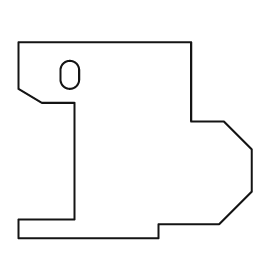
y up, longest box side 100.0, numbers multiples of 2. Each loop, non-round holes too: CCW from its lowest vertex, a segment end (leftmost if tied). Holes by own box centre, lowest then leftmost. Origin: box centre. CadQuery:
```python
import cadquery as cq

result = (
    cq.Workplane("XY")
    .moveTo(-50.0, -42.0)
    .lineTo(10.0, -42.0)
    .lineTo(10.0, -36.0)
    .lineTo(36.0, -36.0)
    .lineTo(50.0, -22.0)
    .lineTo(50.0, -4.0)
    .lineTo(38.0, 8.0)
    .lineTo(24.0, 8.0)
    .lineTo(24.0, 42.0)
    .lineTo(-50.0, 42.0)
    .lineTo(-50.0, 22.0)
    .lineTo(-40.0, 16.0)
    .lineTo(-26.0, 16.0)
    .lineTo(-26.0, -34.0)
    .lineTo(-50.0, -34.0)
    .close()
    .moveTo(-32.0, 26.0)
    .threePointArc((-28.0, 22.0), (-24.0, 26.0))
    .lineTo(-24.0, 30.0)
    .threePointArc((-28.0, 34.0), (-32.0, 30.0))
    .close()
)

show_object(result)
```